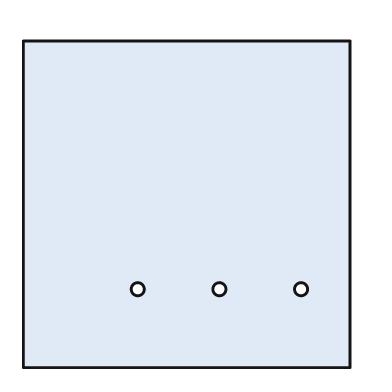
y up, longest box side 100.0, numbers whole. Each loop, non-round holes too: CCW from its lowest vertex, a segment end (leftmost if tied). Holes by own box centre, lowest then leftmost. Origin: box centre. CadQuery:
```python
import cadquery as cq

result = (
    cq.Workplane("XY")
    .moveTo(-50.0, -50.0)
    .lineTo(50.0, -50.0)
    .lineTo(50.0, 50.0)
    .lineTo(-50.0, 50.0)
    .close()
    .moveTo(-15.0, -26.0)
    .circle(2.0)
    .moveTo(10.0, -26.0)
    .circle(2.0)
    .moveTo(35.0, -26.0)
    .circle(2.0)
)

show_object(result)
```